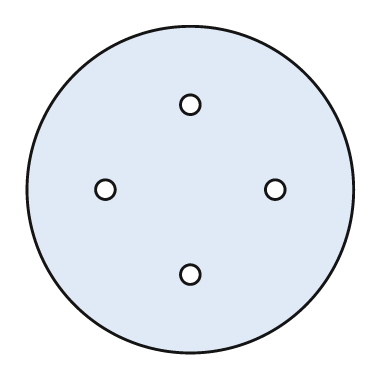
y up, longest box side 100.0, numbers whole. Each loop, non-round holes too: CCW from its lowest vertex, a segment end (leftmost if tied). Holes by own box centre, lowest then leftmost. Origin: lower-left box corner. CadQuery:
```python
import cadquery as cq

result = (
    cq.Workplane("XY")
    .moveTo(50.0, 50.0)
    .circle(50.0)
    .moveTo(50.0, 24.0)
    .circle(3.0)
    .moveTo(24.0, 50.0)
    .circle(3.0)
    .moveTo(76.0, 50.0)
    .circle(3.0)
    .moveTo(50.0, 76.0)
    .circle(3.0)
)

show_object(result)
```